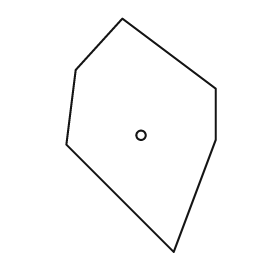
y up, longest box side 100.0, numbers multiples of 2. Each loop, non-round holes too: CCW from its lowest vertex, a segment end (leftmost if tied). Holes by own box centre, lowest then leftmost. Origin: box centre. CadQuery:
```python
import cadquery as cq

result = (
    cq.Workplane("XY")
    .moveTo(14.0, -50.0)
    .lineTo(32.0, -2.0)
    .lineTo(32.0, 20.0)
    .lineTo(-8.0, 50.0)
    .lineTo(-28.0, 28.0)
    .lineTo(-32.0, -4.0)
    .close()
    .moveTo(0.0, 0.0)
    .circle(2.0)
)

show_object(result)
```